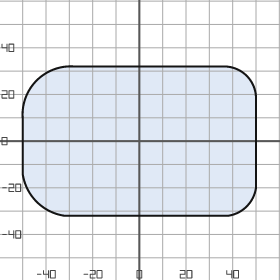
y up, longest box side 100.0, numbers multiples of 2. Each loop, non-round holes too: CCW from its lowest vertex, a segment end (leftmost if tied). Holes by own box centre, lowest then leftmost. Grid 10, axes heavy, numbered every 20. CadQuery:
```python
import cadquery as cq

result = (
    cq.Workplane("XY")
    .moveTo(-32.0, -32.0)
    .lineTo(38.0, -32.0)
    .threePointArc((46.0, -28.0), (50.0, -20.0))
    .lineTo(50.0, 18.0)
    .threePointArc((46.0, 28.0), (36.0, 32.0))
    .lineTo(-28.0, 32.0)
    .threePointArc((-44.0, 26.0), (-50.0, 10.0))
    .lineTo(-50.0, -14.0)
    .threePointArc((-44.0, -26.0), (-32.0, -32.0))
    .close()
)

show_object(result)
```